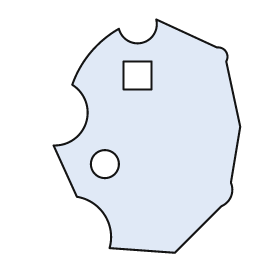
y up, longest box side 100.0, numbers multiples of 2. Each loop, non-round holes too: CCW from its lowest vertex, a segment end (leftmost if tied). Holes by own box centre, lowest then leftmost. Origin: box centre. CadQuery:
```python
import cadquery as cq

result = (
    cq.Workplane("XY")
    .moveTo(12.0, -50.0)
    .lineTo(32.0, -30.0)
    .threePointArc((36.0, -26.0), (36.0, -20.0))
    .lineTo(40.0, 4.0)
    .lineTo(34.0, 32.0)
    .threePointArc((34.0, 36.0), (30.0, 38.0))
    .lineTo(4.0, 50.0)
    .threePointArc((-2.0, 40.0), (-12.0, 46.0))
    .threePointArc((-24.0, 36.0), (-32.0, 22.0))
    .threePointArc((-26.0, 6.0), (-40.0, -4.0))
    .lineTo(-30.0, -26.0)
    .threePointArc((-18.0, -34.0), (-16.0, -48.0))
    .close()
    .moveTo(-18.0, -12.0)
    .circle(6.0)
    .moveTo(-10.0, 20.0)
    .lineTo(2.0, 20.0)
    .lineTo(2.0, 32.0)
    .lineTo(-10.0, 32.0)
    .close()
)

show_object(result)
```